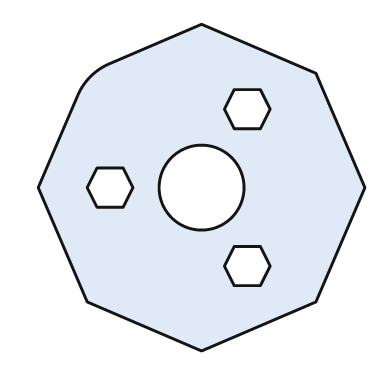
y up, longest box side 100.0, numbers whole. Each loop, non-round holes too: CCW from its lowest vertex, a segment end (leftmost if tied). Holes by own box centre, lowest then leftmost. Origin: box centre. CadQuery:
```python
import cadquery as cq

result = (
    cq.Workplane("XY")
    .moveTo(0.0, -50.0)
    .lineTo(35.0, -35.0)
    .lineTo(50.0, 0.0)
    .lineTo(35.0, 35.0)
    .lineTo(0.0, 50.0)
    .lineTo(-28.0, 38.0)
    .threePointArc((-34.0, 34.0), (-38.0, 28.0))
    .lineTo(-50.0, 0.0)
    .lineTo(-35.0, -35.0)
    .close()
    .moveTo(10.0, -30.0)
    .lineTo(18.0, -30.0)
    .lineTo(21.0, -24.0)
    .lineTo(18.0, -18.0)
    .lineTo(10.0, -18.0)
    .lineTo(7.0, -24.0)
    .close()
    .moveTo(-32.0, -6.0)
    .lineTo(-24.0, -6.0)
    .lineTo(-21.0, 0.0)
    .lineTo(-24.0, 6.0)
    .lineTo(-32.0, 6.0)
    .lineTo(-35.0, 0.0)
    .close()
    .moveTo(0.0, 0.0)
    .circle(13.0)
    .moveTo(10.0, 18.0)
    .lineTo(18.0, 18.0)
    .lineTo(21.0, 24.0)
    .lineTo(18.0, 30.0)
    .lineTo(10.0, 30.0)
    .lineTo(7.0, 24.0)
    .close()
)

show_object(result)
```